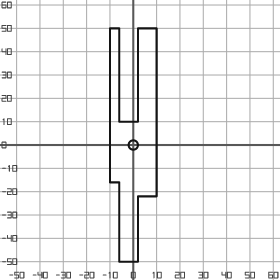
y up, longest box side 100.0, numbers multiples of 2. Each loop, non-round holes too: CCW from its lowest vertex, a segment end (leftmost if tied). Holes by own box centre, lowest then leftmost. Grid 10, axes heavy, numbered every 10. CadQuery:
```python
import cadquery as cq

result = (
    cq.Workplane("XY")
    .moveTo(-6.0, -50.0)
    .lineTo(2.0, -50.0)
    .lineTo(2.0, -22.0)
    .lineTo(10.0, -22.0)
    .lineTo(10.0, 50.0)
    .lineTo(2.0, 50.0)
    .lineTo(2.0, 10.0)
    .lineTo(-6.0, 10.0)
    .lineTo(-6.0, 50.0)
    .lineTo(-10.0, 50.0)
    .lineTo(-10.0, -16.0)
    .lineTo(-6.0, -16.0)
    .close()
    .moveTo(0.0, 0.0)
    .circle(2.0)
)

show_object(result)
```